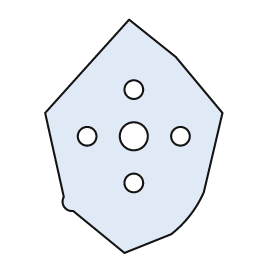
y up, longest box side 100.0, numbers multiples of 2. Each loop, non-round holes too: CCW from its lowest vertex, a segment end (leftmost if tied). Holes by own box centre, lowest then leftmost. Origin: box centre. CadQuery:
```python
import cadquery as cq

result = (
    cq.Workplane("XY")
    .moveTo(-4.0, -50.0)
    .lineTo(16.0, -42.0)
    .threePointArc((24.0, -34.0), (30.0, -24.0))
    .lineTo(38.0, 10.0)
    .lineTo(18.0, 34.0)
    .lineTo(-2.0, 50.0)
    .lineTo(-38.0, 10.0)
    .lineTo(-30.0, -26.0)
    .threePointArc((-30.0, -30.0), (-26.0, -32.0))
    .close()
    .moveTo(0.0, -20.0)
    .circle(4.0)
    .moveTo(-20.0, 0.0)
    .circle(4.0)
    .moveTo(0.0, 0.0)
    .circle(6.0)
    .moveTo(20.0, 0.0)
    .circle(4.0)
    .moveTo(0.0, 20.0)
    .circle(4.0)
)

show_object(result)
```